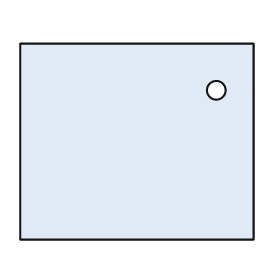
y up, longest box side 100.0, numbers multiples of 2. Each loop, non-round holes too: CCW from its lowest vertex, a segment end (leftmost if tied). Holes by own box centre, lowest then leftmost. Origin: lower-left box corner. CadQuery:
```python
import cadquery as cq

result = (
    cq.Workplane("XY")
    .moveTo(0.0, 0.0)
    .lineTo(100.0, 0.0)
    .lineTo(100.0, 84.0)
    .lineTo(0.0, 84.0)
    .close()
    .moveTo(84.0, 64.0)
    .circle(4.0)
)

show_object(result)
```